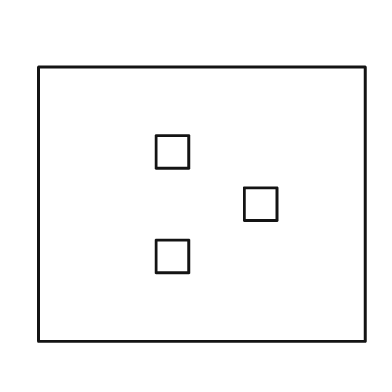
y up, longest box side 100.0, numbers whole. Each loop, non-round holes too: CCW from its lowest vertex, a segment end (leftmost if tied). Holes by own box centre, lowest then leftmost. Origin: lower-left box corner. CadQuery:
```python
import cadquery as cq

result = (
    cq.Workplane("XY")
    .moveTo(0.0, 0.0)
    .lineTo(100.0, 0.0)
    .lineTo(100.0, 84.0)
    .lineTo(0.0, 84.0)
    .close()
    .moveTo(36.0, 21.0)
    .lineTo(46.0, 21.0)
    .lineTo(46.0, 31.0)
    .lineTo(36.0, 31.0)
    .close()
    .moveTo(63.0, 37.0)
    .lineTo(73.0, 37.0)
    .lineTo(73.0, 47.0)
    .lineTo(63.0, 47.0)
    .close()
    .moveTo(36.0, 53.0)
    .lineTo(46.0, 53.0)
    .lineTo(46.0, 63.0)
    .lineTo(36.0, 63.0)
    .close()
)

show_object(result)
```